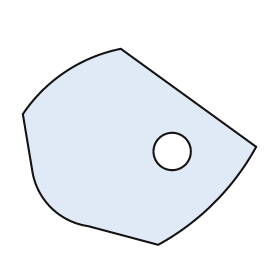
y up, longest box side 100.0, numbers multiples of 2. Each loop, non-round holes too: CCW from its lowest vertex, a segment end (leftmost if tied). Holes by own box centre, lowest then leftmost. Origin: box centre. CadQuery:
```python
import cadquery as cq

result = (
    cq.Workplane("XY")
    .moveTo(8.0, -42.0)
    .threePointArc((32.0, -24.0), (50.0, 0.0))
    .lineTo(-8.0, 42.0)
    .threePointArc((-32.0, 32.0), (-50.0, 14.0))
    .lineTo(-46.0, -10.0)
    .threePointArc((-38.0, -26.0), (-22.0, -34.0))
    .close()
    .moveTo(14.0, -2.0)
    .circle(8.0)
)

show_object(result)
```